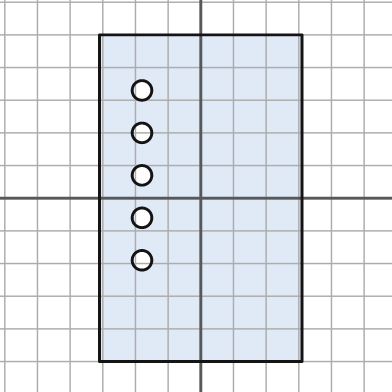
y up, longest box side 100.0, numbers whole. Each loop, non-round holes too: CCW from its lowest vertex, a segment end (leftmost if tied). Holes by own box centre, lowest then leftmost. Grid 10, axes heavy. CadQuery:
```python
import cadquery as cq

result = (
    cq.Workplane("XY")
    .moveTo(-31.0, -50.0)
    .lineTo(31.0, -50.0)
    .lineTo(31.0, 50.0)
    .lineTo(-31.0, 50.0)
    .close()
    .moveTo(-18.0, -19.0)
    .circle(3.0)
    .moveTo(-18.0, -6.0)
    .circle(3.0)
    .moveTo(-18.0, 7.0)
    .circle(3.0)
    .moveTo(-18.0, 20.0)
    .circle(3.0)
    .moveTo(-18.0, 33.0)
    .circle(3.0)
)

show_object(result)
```